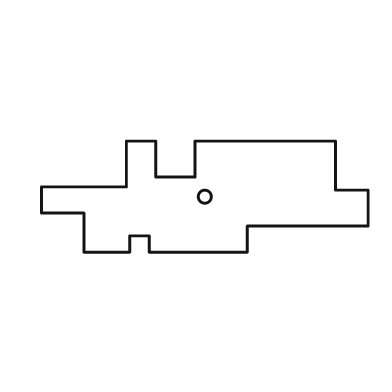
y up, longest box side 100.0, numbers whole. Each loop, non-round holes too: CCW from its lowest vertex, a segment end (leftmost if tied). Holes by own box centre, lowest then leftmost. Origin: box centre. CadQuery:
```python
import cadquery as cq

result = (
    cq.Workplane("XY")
    .moveTo(-37.0, -17.0)
    .lineTo(-23.0, -17.0)
    .lineTo(-23.0, -12.0)
    .lineTo(-17.0, -12.0)
    .lineTo(-17.0, -17.0)
    .lineTo(13.0, -17.0)
    .lineTo(13.0, -9.0)
    .lineTo(50.0, -9.0)
    .lineTo(50.0, 2.0)
    .lineTo(40.0, 2.0)
    .lineTo(40.0, 17.0)
    .lineTo(-3.0, 17.0)
    .lineTo(-3.0, 6.0)
    .lineTo(-15.0, 6.0)
    .lineTo(-15.0, 17.0)
    .lineTo(-24.0, 17.0)
    .lineTo(-24.0, 3.0)
    .lineTo(-50.0, 3.0)
    .lineTo(-50.0, -5.0)
    .lineTo(-37.0, -5.0)
    .close()
    .moveTo(0.0, 0.0)
    .circle(2.0)
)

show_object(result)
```